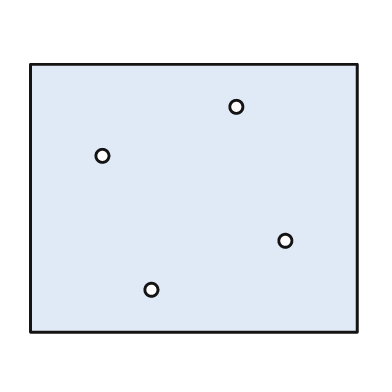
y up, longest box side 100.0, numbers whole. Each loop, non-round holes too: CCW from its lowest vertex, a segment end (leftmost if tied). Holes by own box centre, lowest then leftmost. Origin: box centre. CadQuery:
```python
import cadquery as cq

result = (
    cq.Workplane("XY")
    .moveTo(-50.0, -41.0)
    .lineTo(50.0, -41.0)
    .lineTo(50.0, 41.0)
    .lineTo(-50.0, 41.0)
    .close()
    .moveTo(-13.0, -28.0)
    .circle(2.0)
    .moveTo(28.0, -13.0)
    .circle(2.0)
    .moveTo(-28.0, 13.0)
    .circle(2.0)
    .moveTo(13.0, 28.0)
    .circle(2.0)
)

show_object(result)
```